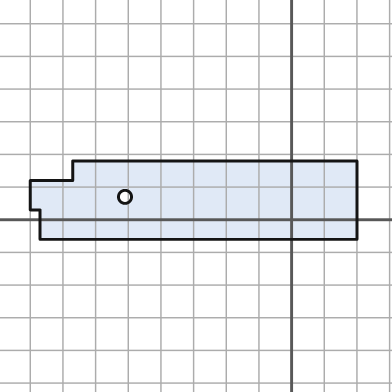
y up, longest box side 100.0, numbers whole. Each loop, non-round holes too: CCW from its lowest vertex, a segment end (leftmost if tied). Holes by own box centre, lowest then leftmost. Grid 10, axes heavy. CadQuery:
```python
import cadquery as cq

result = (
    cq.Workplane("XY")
    .moveTo(-77.0, -6.0)
    .lineTo(20.0, -6.0)
    .lineTo(20.0, 18.0)
    .lineTo(-67.0, 18.0)
    .lineTo(-67.0, 12.0)
    .lineTo(-80.0, 12.0)
    .lineTo(-80.0, 3.0)
    .lineTo(-77.0, 3.0)
    .close()
    .moveTo(-51.0, 7.0)
    .circle(2.0)
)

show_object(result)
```